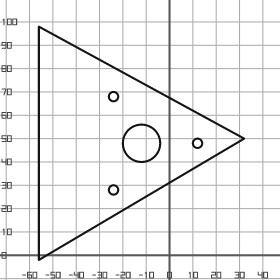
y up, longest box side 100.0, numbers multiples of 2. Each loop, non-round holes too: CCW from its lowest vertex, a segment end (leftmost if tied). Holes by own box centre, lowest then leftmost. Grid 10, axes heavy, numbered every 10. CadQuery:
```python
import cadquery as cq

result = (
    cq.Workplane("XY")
    .moveTo(-56.0, -2.0)
    .lineTo(32.0, 50.0)
    .lineTo(-56.0, 98.0)
    .close()
    .moveTo(-24.0, 28.0)
    .circle(2.0)
    .moveTo(-12.0, 48.0)
    .circle(8.0)
    .moveTo(12.0, 48.0)
    .circle(2.0)
    .moveTo(-24.0, 68.0)
    .circle(2.0)
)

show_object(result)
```